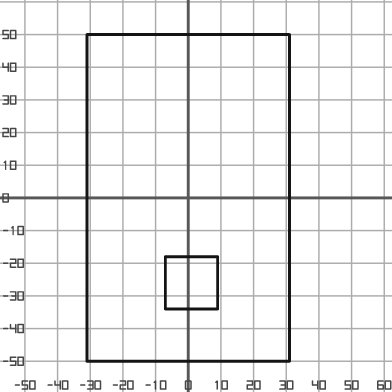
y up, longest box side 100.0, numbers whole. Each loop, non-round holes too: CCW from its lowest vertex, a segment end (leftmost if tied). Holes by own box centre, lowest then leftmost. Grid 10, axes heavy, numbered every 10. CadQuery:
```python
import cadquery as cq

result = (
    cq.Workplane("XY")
    .moveTo(-31.0, -50.0)
    .lineTo(31.0, -50.0)
    .lineTo(31.0, 50.0)
    .lineTo(-31.0, 50.0)
    .close()
    .moveTo(-7.0, -34.0)
    .lineTo(9.0, -34.0)
    .lineTo(9.0, -18.0)
    .lineTo(-7.0, -18.0)
    .close()
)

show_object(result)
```